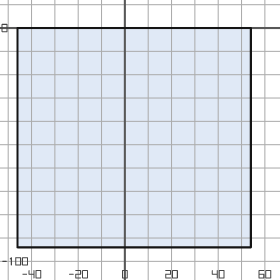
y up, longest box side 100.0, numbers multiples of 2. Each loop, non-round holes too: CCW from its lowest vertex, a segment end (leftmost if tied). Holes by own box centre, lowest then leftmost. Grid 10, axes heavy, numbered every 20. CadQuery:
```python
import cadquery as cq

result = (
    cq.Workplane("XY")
    .moveTo(-46.0, -94.0)
    .lineTo(54.0, -94.0)
    .lineTo(54.0, 0.0)
    .lineTo(-46.0, 0.0)
    .close()
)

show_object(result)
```